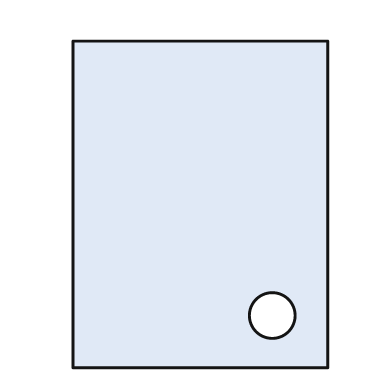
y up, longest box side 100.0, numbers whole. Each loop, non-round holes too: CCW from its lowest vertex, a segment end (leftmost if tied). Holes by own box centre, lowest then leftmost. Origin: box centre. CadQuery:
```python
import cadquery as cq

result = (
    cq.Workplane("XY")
    .moveTo(-39.0, -50.0)
    .lineTo(39.0, -50.0)
    .lineTo(39.0, 50.0)
    .lineTo(-39.0, 50.0)
    .close()
    .moveTo(22.0, -34.0)
    .circle(7.0)
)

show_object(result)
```